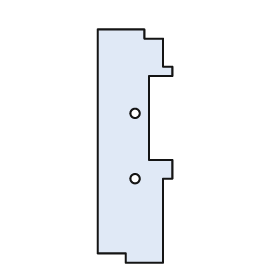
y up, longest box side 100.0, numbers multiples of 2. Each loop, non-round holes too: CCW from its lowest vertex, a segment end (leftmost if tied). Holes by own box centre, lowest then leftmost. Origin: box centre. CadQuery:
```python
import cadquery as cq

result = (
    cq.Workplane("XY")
    .moveTo(-4.0, -50.0)
    .lineTo(12.0, -50.0)
    .lineTo(12.0, -14.0)
    .lineTo(16.0, -14.0)
    .lineTo(16.0, -6.0)
    .lineTo(6.0, -6.0)
    .lineTo(6.0, 30.0)
    .lineTo(16.0, 30.0)
    .lineTo(16.0, 34.0)
    .lineTo(12.0, 34.0)
    .lineTo(12.0, 46.0)
    .lineTo(4.0, 46.0)
    .lineTo(4.0, 50.0)
    .lineTo(-16.0, 50.0)
    .lineTo(-16.0, -46.0)
    .lineTo(-4.0, -46.0)
    .close()
    .moveTo(0.0, -14.0)
    .circle(2.0)
    .moveTo(0.0, 14.0)
    .circle(2.0)
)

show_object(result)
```